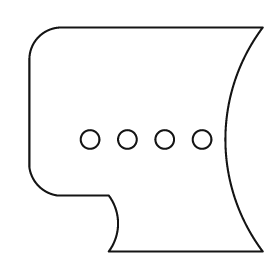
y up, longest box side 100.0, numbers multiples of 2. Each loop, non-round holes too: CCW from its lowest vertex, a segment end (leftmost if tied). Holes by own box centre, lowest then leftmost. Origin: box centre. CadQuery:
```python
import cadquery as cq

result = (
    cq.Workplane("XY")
    .moveTo(-16.0, -48.0)
    .lineTo(50.0, -48.0)
    .threePointArc((34.0, 0.0), (50.0, 48.0))
    .lineTo(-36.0, 48.0)
    .threePointArc((-46.0, 44.0), (-50.0, 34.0))
    .lineTo(-50.0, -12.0)
    .threePointArc((-46.0, -20.0), (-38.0, -24.0))
    .lineTo(-16.0, -24.0)
    .threePointArc((-12.0, -36.0), (-16.0, -48.0))
    .close()
    .moveTo(-24.0, 0.0)
    .circle(4.0)
    .moveTo(-8.0, 0.0)
    .circle(4.0)
    .moveTo(8.0, 0.0)
    .circle(4.0)
    .moveTo(24.0, 0.0)
    .circle(4.0)
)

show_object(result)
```